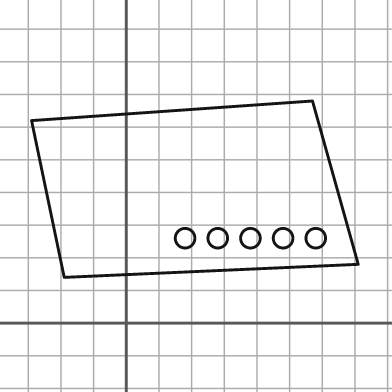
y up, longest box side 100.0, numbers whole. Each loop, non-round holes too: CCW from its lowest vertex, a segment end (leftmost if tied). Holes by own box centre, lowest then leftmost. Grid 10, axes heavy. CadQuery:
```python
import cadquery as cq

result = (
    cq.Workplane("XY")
    .moveTo(-19.0, 14.0)
    .lineTo(71.0, 18.0)
    .lineTo(57.0, 68.0)
    .lineTo(-29.0, 62.0)
    .close()
    .moveTo(18.0, 26.0)
    .circle(3.0)
    .moveTo(28.0, 26.0)
    .circle(3.0)
    .moveTo(38.0, 26.0)
    .circle(3.0)
    .moveTo(48.0, 26.0)
    .circle(3.0)
    .moveTo(58.0, 26.0)
    .circle(3.0)
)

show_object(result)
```